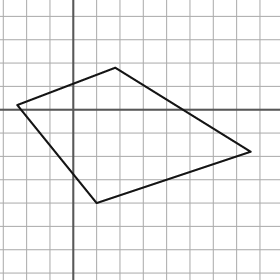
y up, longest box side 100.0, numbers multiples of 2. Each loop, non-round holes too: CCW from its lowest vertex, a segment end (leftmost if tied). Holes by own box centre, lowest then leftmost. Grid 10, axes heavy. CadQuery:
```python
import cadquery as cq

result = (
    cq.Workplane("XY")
    .moveTo(10.0, -40.0)
    .lineTo(76.0, -18.0)
    .lineTo(18.0, 18.0)
    .lineTo(-24.0, 2.0)
    .close()
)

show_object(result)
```